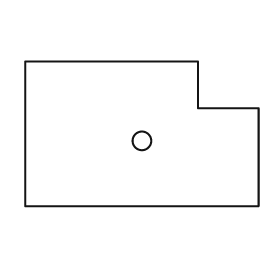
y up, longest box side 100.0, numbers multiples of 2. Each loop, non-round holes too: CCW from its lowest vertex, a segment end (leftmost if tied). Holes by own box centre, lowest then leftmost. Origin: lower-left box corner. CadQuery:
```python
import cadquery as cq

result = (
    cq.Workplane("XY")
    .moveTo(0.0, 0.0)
    .lineTo(100.0, 0.0)
    .lineTo(100.0, 42.0)
    .lineTo(74.0, 42.0)
    .lineTo(74.0, 62.0)
    .lineTo(0.0, 62.0)
    .close()
    .moveTo(50.0, 28.0)
    .circle(4.0)
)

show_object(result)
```